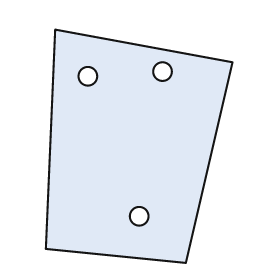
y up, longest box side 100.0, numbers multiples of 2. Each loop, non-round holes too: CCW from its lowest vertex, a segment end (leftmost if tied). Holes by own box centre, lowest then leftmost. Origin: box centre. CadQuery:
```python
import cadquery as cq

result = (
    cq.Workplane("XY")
    .moveTo(20.0, -50.0)
    .lineTo(40.0, 36.0)
    .lineTo(-36.0, 50.0)
    .lineTo(-40.0, -44.0)
    .close()
    .moveTo(0.0, -30.0)
    .circle(4.0)
    .moveTo(-22.0, 30.0)
    .circle(4.0)
    .moveTo(10.0, 32.0)
    .circle(4.0)
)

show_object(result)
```